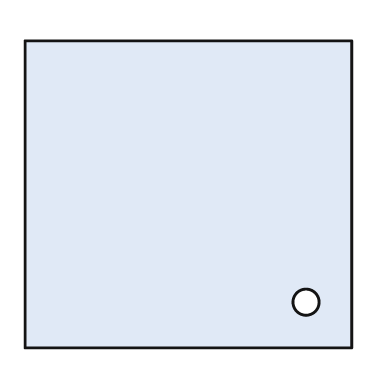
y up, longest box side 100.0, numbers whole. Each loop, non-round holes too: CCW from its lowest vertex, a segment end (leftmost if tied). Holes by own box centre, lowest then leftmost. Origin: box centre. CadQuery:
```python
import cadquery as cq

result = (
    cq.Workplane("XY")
    .moveTo(-50.0, -47.0)
    .lineTo(50.0, -47.0)
    .lineTo(50.0, 47.0)
    .lineTo(-50.0, 47.0)
    .close()
    .moveTo(36.0, -33.0)
    .circle(4.0)
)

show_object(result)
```